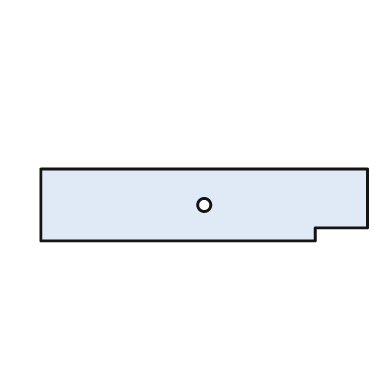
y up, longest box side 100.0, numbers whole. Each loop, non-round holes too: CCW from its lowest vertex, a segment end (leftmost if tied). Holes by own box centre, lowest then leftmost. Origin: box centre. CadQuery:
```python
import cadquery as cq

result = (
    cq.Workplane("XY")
    .moveTo(-50.0, -11.0)
    .lineTo(34.0, -11.0)
    .lineTo(34.0, -7.0)
    .lineTo(50.0, -7.0)
    .lineTo(50.0, 11.0)
    .lineTo(-50.0, 11.0)
    .close()
    .moveTo(0.0, 0.0)
    .circle(2.0)
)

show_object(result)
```